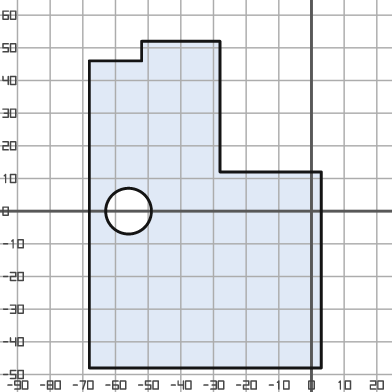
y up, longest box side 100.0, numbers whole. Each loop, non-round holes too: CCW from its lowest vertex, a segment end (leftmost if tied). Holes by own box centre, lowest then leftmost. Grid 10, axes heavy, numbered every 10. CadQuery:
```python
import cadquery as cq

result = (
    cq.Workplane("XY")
    .moveTo(-68.0, -48.0)
    .lineTo(3.0, -48.0)
    .lineTo(3.0, 12.0)
    .lineTo(-28.0, 12.0)
    .lineTo(-28.0, 52.0)
    .lineTo(-52.0, 52.0)
    .lineTo(-52.0, 46.0)
    .lineTo(-68.0, 46.0)
    .close()
    .moveTo(-56.0, 0.0)
    .circle(7.0)
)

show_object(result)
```